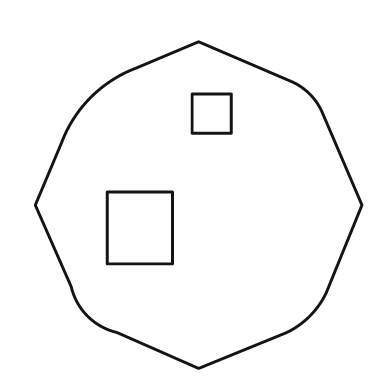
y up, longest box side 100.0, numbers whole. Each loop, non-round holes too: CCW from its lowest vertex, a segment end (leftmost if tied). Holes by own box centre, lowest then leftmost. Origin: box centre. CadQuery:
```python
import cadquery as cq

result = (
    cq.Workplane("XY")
    .moveTo(0.0, -50.0)
    .lineTo(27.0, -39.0)
    .threePointArc((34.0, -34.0), (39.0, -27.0))
    .lineTo(50.0, 0.0)
    .lineTo(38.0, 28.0)
    .threePointArc((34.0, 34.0), (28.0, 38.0))
    .lineTo(0.0, 50.0)
    .lineTo(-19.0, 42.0)
    .threePointArc((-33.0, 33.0), (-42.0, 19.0))
    .lineTo(-50.0, 0.0)
    .lineTo(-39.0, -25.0)
    .threePointArc((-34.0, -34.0), (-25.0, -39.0))
    .close()
    .moveTo(-28.0, -18.0)
    .lineTo(-8.0, -18.0)
    .lineTo(-8.0, 4.0)
    .lineTo(-28.0, 4.0)
    .close()
    .moveTo(-2.0, 22.0)
    .lineTo(10.0, 22.0)
    .lineTo(10.0, 34.0)
    .lineTo(-2.0, 34.0)
    .close()
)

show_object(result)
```